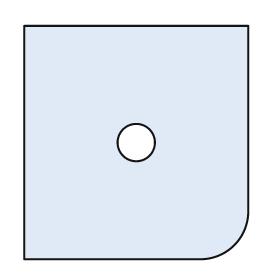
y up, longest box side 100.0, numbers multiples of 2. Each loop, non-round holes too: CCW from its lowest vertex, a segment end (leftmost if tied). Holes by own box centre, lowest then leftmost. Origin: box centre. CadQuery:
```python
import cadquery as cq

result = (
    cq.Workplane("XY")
    .moveTo(-48.0, -50.0)
    .lineTo(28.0, -50.0)
    .threePointArc((42.0, -44.0), (48.0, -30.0))
    .lineTo(48.0, 50.0)
    .lineTo(-48.0, 50.0)
    .close()
    .moveTo(0.0, 0.0)
    .circle(8.0)
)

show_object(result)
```